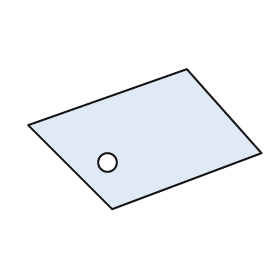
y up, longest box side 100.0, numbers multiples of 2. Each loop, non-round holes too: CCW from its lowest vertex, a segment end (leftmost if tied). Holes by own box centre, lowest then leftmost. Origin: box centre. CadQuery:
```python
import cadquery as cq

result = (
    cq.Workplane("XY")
    .moveTo(-14.0, -30.0)
    .lineTo(50.0, -6.0)
    .lineTo(18.0, 30.0)
    .lineTo(-50.0, 6.0)
    .close()
    .moveTo(-16.0, -10.0)
    .circle(4.0)
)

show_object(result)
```